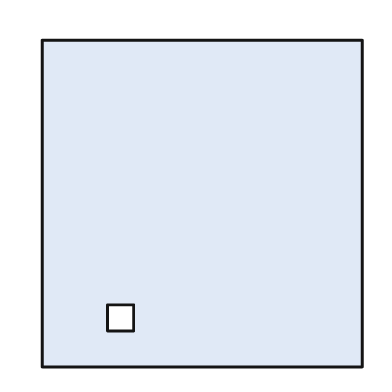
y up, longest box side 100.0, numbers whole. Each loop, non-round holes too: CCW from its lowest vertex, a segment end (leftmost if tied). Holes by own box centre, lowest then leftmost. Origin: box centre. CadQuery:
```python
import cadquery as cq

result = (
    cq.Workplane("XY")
    .moveTo(-49.0, -50.0)
    .lineTo(49.0, -50.0)
    .lineTo(49.0, 50.0)
    .lineTo(-49.0, 50.0)
    .close()
    .moveTo(-29.0, -39.0)
    .lineTo(-21.0, -39.0)
    .lineTo(-21.0, -31.0)
    .lineTo(-29.0, -31.0)
    .close()
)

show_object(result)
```